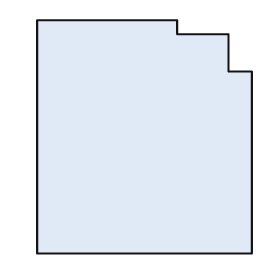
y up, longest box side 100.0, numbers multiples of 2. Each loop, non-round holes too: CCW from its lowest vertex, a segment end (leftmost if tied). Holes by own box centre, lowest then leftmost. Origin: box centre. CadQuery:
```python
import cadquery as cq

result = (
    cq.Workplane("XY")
    .moveTo(-46.0, -50.0)
    .lineTo(46.0, -50.0)
    .lineTo(46.0, 28.0)
    .lineTo(36.0, 28.0)
    .lineTo(36.0, 44.0)
    .lineTo(14.0, 44.0)
    .lineTo(14.0, 50.0)
    .lineTo(-46.0, 50.0)
    .close()
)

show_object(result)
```